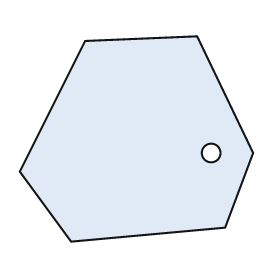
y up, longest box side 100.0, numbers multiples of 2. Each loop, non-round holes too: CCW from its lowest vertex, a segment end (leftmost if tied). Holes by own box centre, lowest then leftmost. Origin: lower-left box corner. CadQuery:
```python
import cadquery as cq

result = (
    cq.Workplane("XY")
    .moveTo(22.0, 0.0)
    .lineTo(88.0, 6.0)
    .lineTo(100.0, 38.0)
    .lineTo(76.0, 88.0)
    .lineTo(28.0, 86.0)
    .lineTo(0.0, 30.0)
    .close()
    .moveTo(82.0, 38.0)
    .circle(4.0)
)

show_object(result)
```